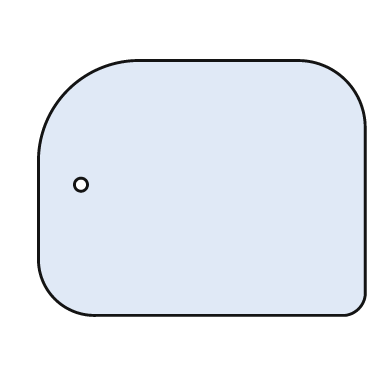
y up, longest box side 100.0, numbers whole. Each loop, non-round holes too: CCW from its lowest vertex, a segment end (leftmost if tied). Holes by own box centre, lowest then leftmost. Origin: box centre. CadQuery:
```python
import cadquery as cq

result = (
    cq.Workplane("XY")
    .moveTo(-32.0, -39.0)
    .lineTo(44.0, -39.0)
    .threePointArc((48.0, -37.0), (50.0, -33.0))
    .lineTo(50.0, 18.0)
    .threePointArc((44.0, 33.0), (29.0, 39.0))
    .lineTo(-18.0, 39.0)
    .threePointArc((-41.0, 30.0), (-50.0, 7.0))
    .lineTo(-50.0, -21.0)
    .threePointArc((-45.0, -34.0), (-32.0, -39.0))
    .close()
    .moveTo(-37.0, 1.0)
    .circle(2.0)
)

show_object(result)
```